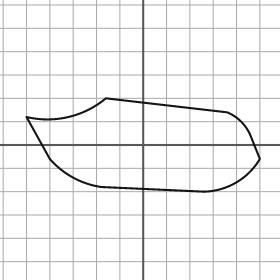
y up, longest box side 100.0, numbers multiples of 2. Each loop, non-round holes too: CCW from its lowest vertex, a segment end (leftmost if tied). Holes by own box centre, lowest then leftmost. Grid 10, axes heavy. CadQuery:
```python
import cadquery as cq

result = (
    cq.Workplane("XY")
    .moveTo(26.0, -20.0)
    .threePointArc((40.0, -16.0), (50.0, -6.0))
    .lineTo(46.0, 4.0)
    .threePointArc((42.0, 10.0), (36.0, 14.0))
    .lineTo(-16.0, 20.0)
    .threePointArc((-32.0, 12.0), (-50.0, 12.0))
    .lineTo(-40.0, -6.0)
    .threePointArc((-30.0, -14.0), (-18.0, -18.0))
    .close()
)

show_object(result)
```